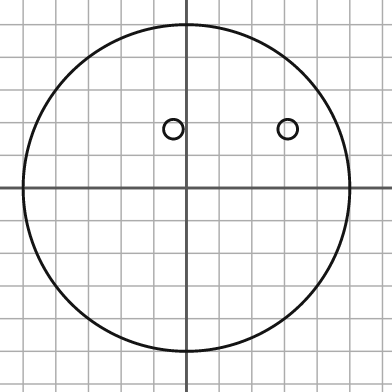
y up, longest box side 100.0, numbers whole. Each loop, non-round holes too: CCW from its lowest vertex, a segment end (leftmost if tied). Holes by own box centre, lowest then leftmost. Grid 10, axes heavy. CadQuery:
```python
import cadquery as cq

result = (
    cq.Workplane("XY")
    .moveTo(0.0, 0.0)
    .circle(50.0)
    .moveTo(-4.0, 18.0)
    .circle(3.0)
    .moveTo(31.0, 18.0)
    .circle(3.0)
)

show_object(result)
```